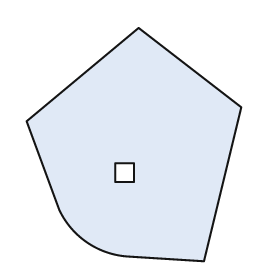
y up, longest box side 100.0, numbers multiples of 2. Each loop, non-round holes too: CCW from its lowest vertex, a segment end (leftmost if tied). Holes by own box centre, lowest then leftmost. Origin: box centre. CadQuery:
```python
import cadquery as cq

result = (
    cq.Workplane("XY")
    .moveTo(30.0, -50.0)
    .lineTo(46.0, 16.0)
    .lineTo(2.0, 50.0)
    .lineTo(-46.0, 10.0)
    .lineTo(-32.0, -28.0)
    .threePointArc((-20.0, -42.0), (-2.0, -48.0))
    .close()
    .moveTo(-8.0, -16.0)
    .lineTo(0.0, -16.0)
    .lineTo(0.0, -8.0)
    .lineTo(-8.0, -8.0)
    .close()
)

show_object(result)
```